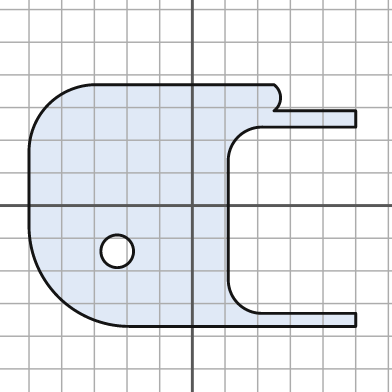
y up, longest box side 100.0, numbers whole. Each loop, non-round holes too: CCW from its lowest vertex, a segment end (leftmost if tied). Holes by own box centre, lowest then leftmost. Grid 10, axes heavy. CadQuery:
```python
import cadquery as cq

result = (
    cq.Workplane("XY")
    .moveTo(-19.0, -37.0)
    .lineTo(50.0, -37.0)
    .lineTo(50.0, -33.0)
    .lineTo(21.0, -33.0)
    .threePointArc((14.0, -30.0), (11.0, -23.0))
    .lineTo(11.0, 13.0)
    .threePointArc((14.0, 21.0), (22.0, 24.0))
    .lineTo(50.0, 24.0)
    .lineTo(50.0, 29.0)
    .lineTo(25.0, 29.0)
    .threePointArc((27.0, 33.0), (25.0, 37.0))
    .lineTo(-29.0, 37.0)
    .threePointArc((-44.0, 31.0), (-50.0, 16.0))
    .lineTo(-50.0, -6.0)
    .threePointArc((-41.0, -28.0), (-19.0, -37.0))
    .close()
    .moveTo(-23.0, -14.0)
    .circle(5.0)
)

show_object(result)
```